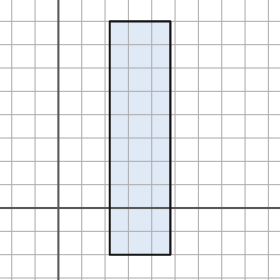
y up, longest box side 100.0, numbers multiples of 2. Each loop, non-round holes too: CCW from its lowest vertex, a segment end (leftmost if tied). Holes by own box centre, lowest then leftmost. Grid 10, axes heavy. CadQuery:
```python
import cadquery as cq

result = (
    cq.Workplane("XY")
    .moveTo(22.0, -20.0)
    .lineTo(48.0, -20.0)
    .lineTo(48.0, 80.0)
    .lineTo(22.0, 80.0)
    .close()
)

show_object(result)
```